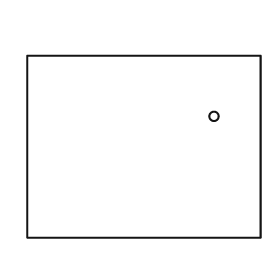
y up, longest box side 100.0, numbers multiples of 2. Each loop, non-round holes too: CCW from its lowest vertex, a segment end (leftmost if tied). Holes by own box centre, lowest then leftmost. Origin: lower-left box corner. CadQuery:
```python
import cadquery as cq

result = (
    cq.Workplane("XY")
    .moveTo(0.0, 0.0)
    .lineTo(100.0, 0.0)
    .lineTo(100.0, 78.0)
    .lineTo(0.0, 78.0)
    .close()
    .moveTo(80.0, 52.0)
    .circle(2.0)
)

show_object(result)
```